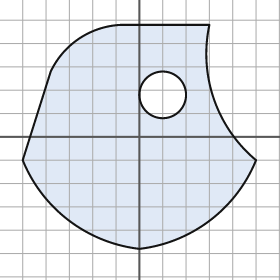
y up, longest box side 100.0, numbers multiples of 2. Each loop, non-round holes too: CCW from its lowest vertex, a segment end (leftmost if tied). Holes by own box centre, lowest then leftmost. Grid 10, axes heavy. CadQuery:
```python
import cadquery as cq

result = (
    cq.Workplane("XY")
    .moveTo(0.0, -48.0)
    .threePointArc((30.0, -36.0), (50.0, -10.0))
    .threePointArc((32.0, 16.0), (30.0, 48.0))
    .lineTo(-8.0, 48.0)
    .threePointArc((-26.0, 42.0), (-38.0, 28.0))
    .lineTo(-50.0, -10.0)
    .threePointArc((-30.0, -36.0), (0.0, -48.0))
    .close()
    .moveTo(10.0, 18.0)
    .circle(10.0)
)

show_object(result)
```